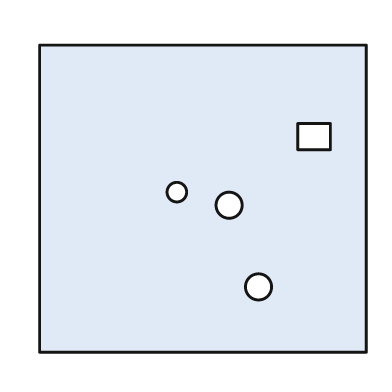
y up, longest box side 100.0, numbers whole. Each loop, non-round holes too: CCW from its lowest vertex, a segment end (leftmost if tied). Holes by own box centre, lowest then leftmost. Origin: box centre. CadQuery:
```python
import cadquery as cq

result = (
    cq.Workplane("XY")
    .moveTo(-50.0, -47.0)
    .lineTo(50.0, -47.0)
    .lineTo(50.0, 47.0)
    .lineTo(-50.0, 47.0)
    .close()
    .moveTo(17.0, -27.0)
    .circle(4.0)
    .moveTo(8.0, -2.0)
    .circle(4.0)
    .moveTo(-8.0, 2.0)
    .circle(3.0)
    .moveTo(29.0, 15.0)
    .lineTo(39.0, 15.0)
    .lineTo(39.0, 23.0)
    .lineTo(29.0, 23.0)
    .close()
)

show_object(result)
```